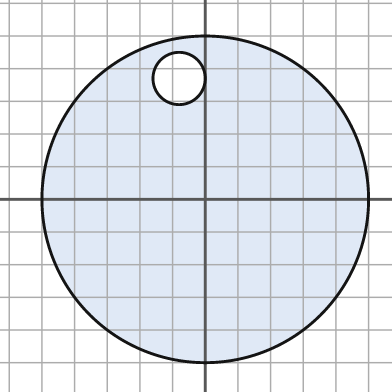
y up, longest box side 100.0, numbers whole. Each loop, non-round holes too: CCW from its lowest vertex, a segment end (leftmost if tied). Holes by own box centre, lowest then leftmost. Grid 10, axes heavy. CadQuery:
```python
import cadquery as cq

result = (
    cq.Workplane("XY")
    .moveTo(0.0, 0.0)
    .circle(50.0)
    .moveTo(-8.0, 37.0)
    .circle(8.0)
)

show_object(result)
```